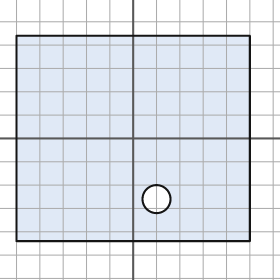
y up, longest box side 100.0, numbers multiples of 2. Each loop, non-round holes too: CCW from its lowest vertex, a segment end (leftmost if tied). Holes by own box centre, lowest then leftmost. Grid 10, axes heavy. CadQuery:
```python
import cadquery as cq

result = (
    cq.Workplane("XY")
    .moveTo(-50.0, -44.0)
    .lineTo(50.0, -44.0)
    .lineTo(50.0, 44.0)
    .lineTo(-50.0, 44.0)
    .close()
    .moveTo(10.0, -26.0)
    .circle(6.0)
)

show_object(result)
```